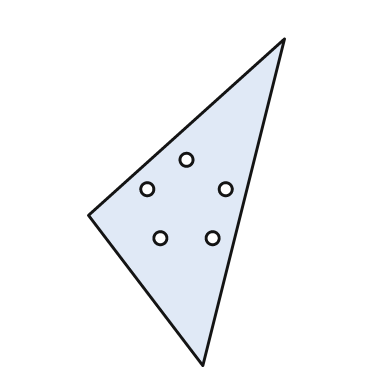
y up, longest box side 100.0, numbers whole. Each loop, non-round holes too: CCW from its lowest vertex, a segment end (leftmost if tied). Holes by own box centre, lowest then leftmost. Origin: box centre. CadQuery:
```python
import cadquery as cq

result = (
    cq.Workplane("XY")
    .moveTo(5.0, -50.0)
    .lineTo(30.0, 50.0)
    .lineTo(-30.0, -4.0)
    .close()
    .moveTo(-8.0, -11.0)
    .circle(2.0)
    .moveTo(8.0, -11.0)
    .circle(2.0)
    .moveTo(-12.0, 4.0)
    .circle(2.0)
    .moveTo(12.0, 4.0)
    .circle(2.0)
    .moveTo(0.0, 13.0)
    .circle(2.0)
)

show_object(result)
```